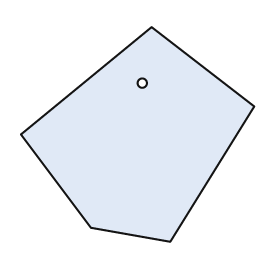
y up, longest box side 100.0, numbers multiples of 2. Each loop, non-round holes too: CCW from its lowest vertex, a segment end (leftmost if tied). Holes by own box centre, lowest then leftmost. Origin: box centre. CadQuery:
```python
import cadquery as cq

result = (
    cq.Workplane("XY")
    .moveTo(14.0, -46.0)
    .lineTo(50.0, 12.0)
    .lineTo(6.0, 46.0)
    .lineTo(-50.0, 0.0)
    .lineTo(-20.0, -40.0)
    .close()
    .moveTo(2.0, 22.0)
    .circle(2.0)
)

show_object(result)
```